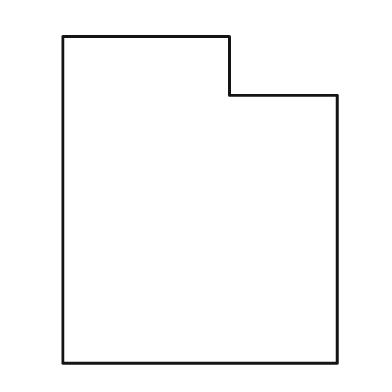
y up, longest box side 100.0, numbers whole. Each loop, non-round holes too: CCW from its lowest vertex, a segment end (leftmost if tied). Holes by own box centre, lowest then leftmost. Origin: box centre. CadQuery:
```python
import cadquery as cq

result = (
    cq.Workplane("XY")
    .moveTo(-42.0, -50.0)
    .lineTo(42.0, -50.0)
    .lineTo(42.0, 32.0)
    .lineTo(9.0, 32.0)
    .lineTo(9.0, 50.0)
    .lineTo(-42.0, 50.0)
    .close()
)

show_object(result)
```